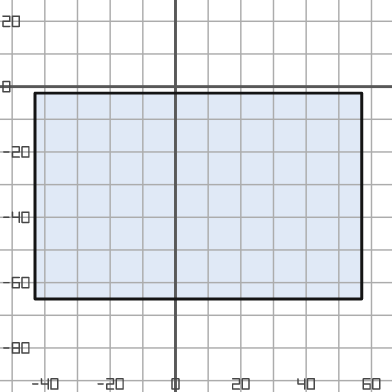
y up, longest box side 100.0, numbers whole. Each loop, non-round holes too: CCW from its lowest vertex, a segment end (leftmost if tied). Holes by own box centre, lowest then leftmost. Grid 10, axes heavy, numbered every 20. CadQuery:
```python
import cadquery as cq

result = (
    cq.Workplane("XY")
    .moveTo(-43.0, -65.0)
    .lineTo(57.0, -65.0)
    .lineTo(57.0, -2.0)
    .lineTo(-43.0, -2.0)
    .close()
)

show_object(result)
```